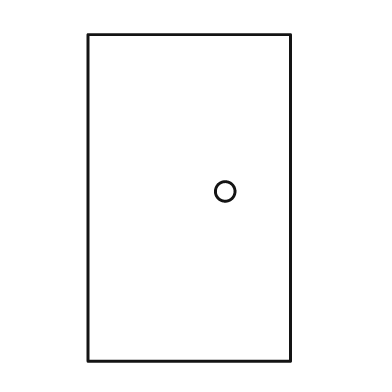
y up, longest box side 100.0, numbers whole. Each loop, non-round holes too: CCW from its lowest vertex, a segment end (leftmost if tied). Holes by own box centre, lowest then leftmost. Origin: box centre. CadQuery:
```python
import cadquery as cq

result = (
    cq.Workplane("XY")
    .moveTo(-31.0, -50.0)
    .lineTo(31.0, -50.0)
    .lineTo(31.0, 50.0)
    .lineTo(-31.0, 50.0)
    .close()
    .moveTo(11.0, 2.0)
    .circle(3.0)
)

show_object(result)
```